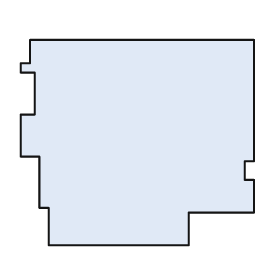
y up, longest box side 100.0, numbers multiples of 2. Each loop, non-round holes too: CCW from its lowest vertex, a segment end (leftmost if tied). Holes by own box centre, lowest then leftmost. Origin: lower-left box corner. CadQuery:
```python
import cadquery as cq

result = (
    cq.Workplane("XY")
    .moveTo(12.0, 0.0)
    .lineTo(72.0, 0.0)
    .lineTo(72.0, 14.0)
    .lineTo(100.0, 14.0)
    .lineTo(100.0, 28.0)
    .lineTo(96.0, 28.0)
    .lineTo(96.0, 36.0)
    .lineTo(100.0, 36.0)
    .lineTo(100.0, 88.0)
    .lineTo(4.0, 88.0)
    .lineTo(4.0, 78.0)
    .lineTo(0.0, 78.0)
    .lineTo(0.0, 74.0)
    .lineTo(6.0, 74.0)
    .lineTo(6.0, 56.0)
    .lineTo(0.0, 56.0)
    .lineTo(0.0, 38.0)
    .lineTo(8.0, 38.0)
    .lineTo(8.0, 16.0)
    .lineTo(12.0, 16.0)
    .close()
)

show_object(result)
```